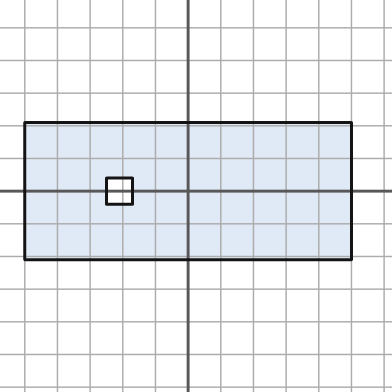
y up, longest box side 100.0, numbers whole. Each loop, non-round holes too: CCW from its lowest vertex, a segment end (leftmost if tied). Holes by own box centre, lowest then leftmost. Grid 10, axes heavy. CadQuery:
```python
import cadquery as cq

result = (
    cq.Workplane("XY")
    .moveTo(-50.0, -21.0)
    .lineTo(50.0, -21.0)
    .lineTo(50.0, 21.0)
    .lineTo(-50.0, 21.0)
    .close()
    .moveTo(-25.0, -4.0)
    .lineTo(-17.0, -4.0)
    .lineTo(-17.0, 4.0)
    .lineTo(-25.0, 4.0)
    .close()
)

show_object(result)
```